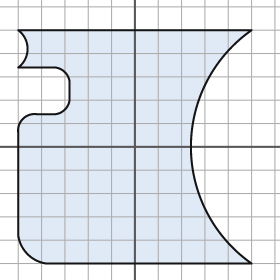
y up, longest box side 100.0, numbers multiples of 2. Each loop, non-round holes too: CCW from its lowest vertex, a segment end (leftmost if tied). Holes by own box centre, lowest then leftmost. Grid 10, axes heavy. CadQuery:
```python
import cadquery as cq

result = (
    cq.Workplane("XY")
    .moveTo(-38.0, -50.0)
    .lineTo(50.0, -50.0)
    .threePointArc((24.0, 0.0), (50.0, 50.0))
    .lineTo(-50.0, 50.0)
    .threePointArc((-46.0, 42.0), (-50.0, 34.0))
    .lineTo(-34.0, 34.0)
    .threePointArc((-30.0, 32.0), (-28.0, 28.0))
    .lineTo(-28.0, 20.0)
    .threePointArc((-30.0, 16.0), (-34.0, 14.0))
    .lineTo(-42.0, 14.0)
    .threePointArc((-48.0, 12.0), (-50.0, 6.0))
    .lineTo(-50.0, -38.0)
    .threePointArc((-46.0, -46.0), (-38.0, -50.0))
    .close()
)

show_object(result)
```